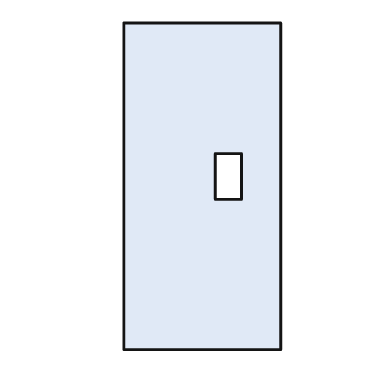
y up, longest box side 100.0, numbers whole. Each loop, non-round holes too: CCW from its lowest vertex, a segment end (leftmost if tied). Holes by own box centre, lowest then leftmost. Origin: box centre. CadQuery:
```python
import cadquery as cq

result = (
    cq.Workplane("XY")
    .moveTo(-24.0, -50.0)
    .lineTo(24.0, -50.0)
    .lineTo(24.0, 50.0)
    .lineTo(-24.0, 50.0)
    .close()
    .moveTo(4.0, -4.0)
    .lineTo(12.0, -4.0)
    .lineTo(12.0, 10.0)
    .lineTo(4.0, 10.0)
    .close()
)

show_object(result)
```